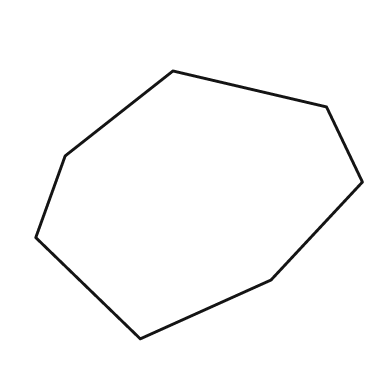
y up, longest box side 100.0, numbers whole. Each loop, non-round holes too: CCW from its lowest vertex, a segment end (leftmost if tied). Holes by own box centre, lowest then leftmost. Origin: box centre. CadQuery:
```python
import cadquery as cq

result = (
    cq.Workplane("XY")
    .moveTo(-18.0, -41.0)
    .lineTo(22.0, -23.0)
    .lineTo(50.0, 7.0)
    .lineTo(39.0, 30.0)
    .lineTo(-8.0, 41.0)
    .lineTo(-41.0, 15.0)
    .lineTo(-50.0, -10.0)
    .close()
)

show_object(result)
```